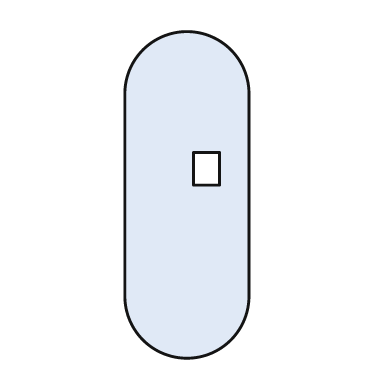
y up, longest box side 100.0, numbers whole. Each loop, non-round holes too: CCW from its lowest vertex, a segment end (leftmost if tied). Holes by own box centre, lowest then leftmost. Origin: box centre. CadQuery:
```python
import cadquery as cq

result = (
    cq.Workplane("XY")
    .moveTo(-19.0, -31.0)
    .threePointArc((0.0, -50.0), (19.0, -31.0))
    .lineTo(19.0, 31.0)
    .threePointArc((0.0, 50.0), (-19.0, 31.0))
    .close()
    .moveTo(2.0, 3.0)
    .lineTo(10.0, 3.0)
    .lineTo(10.0, 13.0)
    .lineTo(2.0, 13.0)
    .close()
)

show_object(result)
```